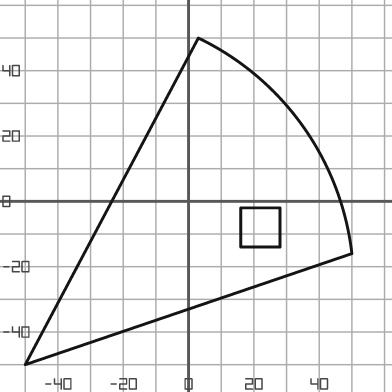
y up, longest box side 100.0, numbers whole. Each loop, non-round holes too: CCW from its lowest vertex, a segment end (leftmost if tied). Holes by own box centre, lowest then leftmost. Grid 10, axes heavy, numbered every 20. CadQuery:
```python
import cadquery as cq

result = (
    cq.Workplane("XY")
    .moveTo(-50.0, -50.0)
    .lineTo(50.0, -16.0)
    .threePointArc((35.0, 23.0), (3.0, 50.0))
    .close()
    .moveTo(16.0, -14.0)
    .lineTo(28.0, -14.0)
    .lineTo(28.0, -2.0)
    .lineTo(16.0, -2.0)
    .close()
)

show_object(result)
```